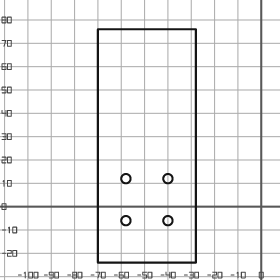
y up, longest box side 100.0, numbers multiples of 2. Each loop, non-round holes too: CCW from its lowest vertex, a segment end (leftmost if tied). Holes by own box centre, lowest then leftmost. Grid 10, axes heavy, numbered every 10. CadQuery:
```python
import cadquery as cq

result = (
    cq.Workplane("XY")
    .moveTo(-70.0, -24.0)
    .lineTo(-28.0, -24.0)
    .lineTo(-28.0, 76.0)
    .lineTo(-70.0, 76.0)
    .close()
    .moveTo(-58.0, -6.0)
    .circle(2.0)
    .moveTo(-40.0, -6.0)
    .circle(2.0)
    .moveTo(-58.0, 12.0)
    .circle(2.0)
    .moveTo(-40.0, 12.0)
    .circle(2.0)
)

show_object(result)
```